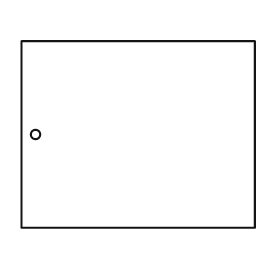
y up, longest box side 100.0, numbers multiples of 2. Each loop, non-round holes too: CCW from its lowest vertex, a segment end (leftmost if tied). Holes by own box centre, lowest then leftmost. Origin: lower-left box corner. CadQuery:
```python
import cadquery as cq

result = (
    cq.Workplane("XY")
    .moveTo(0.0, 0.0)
    .lineTo(100.0, 0.0)
    .lineTo(100.0, 80.0)
    .lineTo(0.0, 80.0)
    .close()
    .moveTo(6.0, 40.0)
    .circle(2.0)
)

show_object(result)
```